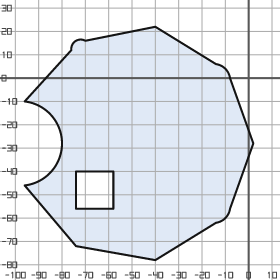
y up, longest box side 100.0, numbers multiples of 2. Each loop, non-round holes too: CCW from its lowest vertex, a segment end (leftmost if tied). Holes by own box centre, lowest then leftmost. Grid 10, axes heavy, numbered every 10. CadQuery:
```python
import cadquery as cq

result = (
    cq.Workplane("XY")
    .moveTo(-40.0, -78.0)
    .lineTo(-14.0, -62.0)
    .threePointArc((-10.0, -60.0), (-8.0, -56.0))
    .lineTo(2.0, -28.0)
    .lineTo(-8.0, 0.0)
    .threePointArc((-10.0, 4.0), (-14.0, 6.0))
    .lineTo(-40.0, 22.0)
    .lineTo(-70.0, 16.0)
    .threePointArc((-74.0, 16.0), (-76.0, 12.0))
    .lineTo(-96.0, -10.0)
    .threePointArc((-80.0, -28.0), (-96.0, -46.0))
    .lineTo(-74.0, -72.0)
    .close()
    .moveTo(-74.0, -56.0)
    .lineTo(-58.0, -56.0)
    .lineTo(-58.0, -40.0)
    .lineTo(-74.0, -40.0)
    .close()
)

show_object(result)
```